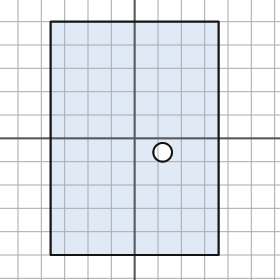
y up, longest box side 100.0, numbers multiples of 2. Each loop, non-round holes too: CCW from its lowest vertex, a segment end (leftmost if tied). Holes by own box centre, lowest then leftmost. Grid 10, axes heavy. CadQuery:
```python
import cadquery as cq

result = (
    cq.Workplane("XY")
    .moveTo(-36.0, -50.0)
    .lineTo(36.0, -50.0)
    .lineTo(36.0, 50.0)
    .lineTo(-36.0, 50.0)
    .close()
    .moveTo(12.0, -6.0)
    .circle(4.0)
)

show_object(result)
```